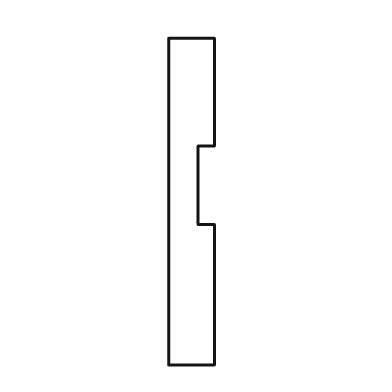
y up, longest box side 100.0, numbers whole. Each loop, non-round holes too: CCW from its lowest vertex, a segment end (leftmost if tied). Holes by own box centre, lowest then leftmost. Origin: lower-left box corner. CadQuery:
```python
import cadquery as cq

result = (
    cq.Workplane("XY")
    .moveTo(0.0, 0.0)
    .lineTo(14.0, 0.0)
    .lineTo(14.0, 43.0)
    .lineTo(9.0, 43.0)
    .lineTo(9.0, 67.0)
    .lineTo(14.0, 67.0)
    .lineTo(14.0, 100.0)
    .lineTo(0.0, 100.0)
    .close()
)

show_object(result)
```